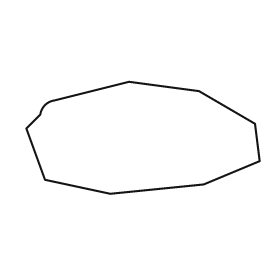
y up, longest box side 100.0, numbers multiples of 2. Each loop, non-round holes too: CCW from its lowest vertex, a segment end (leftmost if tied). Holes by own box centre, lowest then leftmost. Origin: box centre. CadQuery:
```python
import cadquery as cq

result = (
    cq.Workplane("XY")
    .moveTo(-14.0, -24.0)
    .lineTo(26.0, -20.0)
    .lineTo(50.0, -10.0)
    .lineTo(48.0, 6.0)
    .lineTo(24.0, 20.0)
    .lineTo(-6.0, 24.0)
    .lineTo(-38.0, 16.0)
    .threePointArc((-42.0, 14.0), (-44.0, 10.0))
    .lineTo(-50.0, 4.0)
    .lineTo(-42.0, -18.0)
    .close()
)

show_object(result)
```